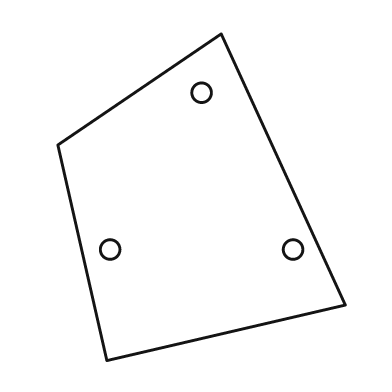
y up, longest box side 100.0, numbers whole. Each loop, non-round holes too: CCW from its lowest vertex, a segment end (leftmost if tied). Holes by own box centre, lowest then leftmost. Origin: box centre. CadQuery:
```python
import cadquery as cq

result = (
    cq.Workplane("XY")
    .moveTo(-29.0, -50.0)
    .lineTo(44.0, -33.0)
    .lineTo(6.0, 50.0)
    .lineTo(-44.0, 16.0)
    .close()
    .moveTo(-28.0, -16.0)
    .circle(3.0)
    .moveTo(28.0, -16.0)
    .circle(3.0)
    .moveTo(0.0, 32.0)
    .circle(3.0)
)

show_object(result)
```